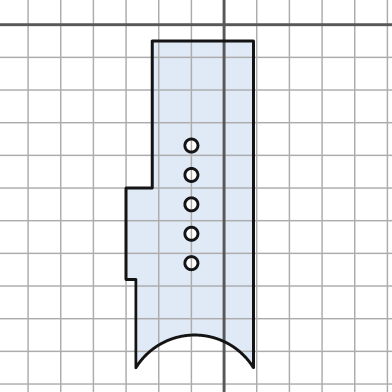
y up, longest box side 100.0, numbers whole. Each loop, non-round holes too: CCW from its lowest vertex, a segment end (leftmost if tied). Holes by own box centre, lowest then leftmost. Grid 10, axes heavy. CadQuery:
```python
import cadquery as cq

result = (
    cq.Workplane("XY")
    .moveTo(-27.0, -105.0)
    .threePointArc((-9.0, -95.0), (9.0, -105.0))
    .lineTo(9.0, -5.0)
    .lineTo(-22.0, -5.0)
    .lineTo(-22.0, -50.0)
    .lineTo(-30.0, -50.0)
    .lineTo(-30.0, -78.0)
    .lineTo(-27.0, -78.0)
    .close()
    .moveTo(-10.0, -73.0)
    .circle(2.0)
    .moveTo(-10.0, -64.0)
    .circle(2.0)
    .moveTo(-10.0, -55.0)
    .circle(2.0)
    .moveTo(-10.0, -46.0)
    .circle(2.0)
    .moveTo(-10.0, -37.0)
    .circle(2.0)
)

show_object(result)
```